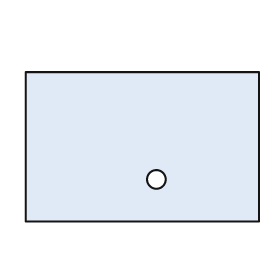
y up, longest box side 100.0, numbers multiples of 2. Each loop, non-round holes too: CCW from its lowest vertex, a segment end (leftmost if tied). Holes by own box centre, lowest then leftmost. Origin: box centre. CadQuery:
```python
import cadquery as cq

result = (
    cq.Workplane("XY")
    .moveTo(-50.0, -32.0)
    .lineTo(50.0, -32.0)
    .lineTo(50.0, 32.0)
    .lineTo(-50.0, 32.0)
    .close()
    .moveTo(6.0, -14.0)
    .circle(4.0)
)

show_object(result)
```